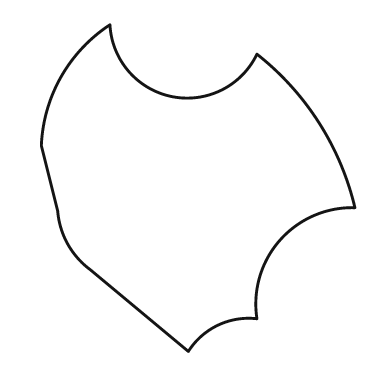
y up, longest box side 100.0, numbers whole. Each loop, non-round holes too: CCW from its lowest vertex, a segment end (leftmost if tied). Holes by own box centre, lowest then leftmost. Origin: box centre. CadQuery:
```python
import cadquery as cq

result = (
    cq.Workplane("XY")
    .moveTo(-3.0, -50.0)
    .threePointArc((6.0, -42.0), (18.0, -40.0))
    .threePointArc((25.0, -16.0), (48.0, -6.0))
    .threePointArc((37.0, 20.0), (18.0, 41.0))
    .threePointArc((-8.0, 28.0), (-27.0, 50.0))
    .threePointArc((-42.0, 34.0), (-48.0, 13.0))
    .lineTo(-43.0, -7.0)
    .threePointArc((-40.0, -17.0), (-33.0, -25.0))
    .close()
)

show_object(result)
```